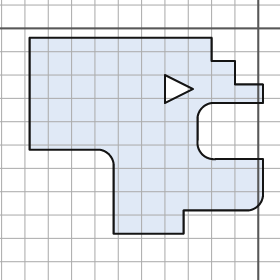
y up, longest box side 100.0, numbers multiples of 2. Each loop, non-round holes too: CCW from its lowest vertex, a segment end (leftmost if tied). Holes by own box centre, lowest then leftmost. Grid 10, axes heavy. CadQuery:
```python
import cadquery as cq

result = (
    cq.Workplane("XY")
    .moveTo(-62.0, -88.0)
    .lineTo(-32.0, -88.0)
    .lineTo(-32.0, -78.0)
    .lineTo(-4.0, -78.0)
    .threePointArc((0.0, -76.0), (2.0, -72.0))
    .lineTo(2.0, -56.0)
    .lineTo(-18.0, -56.0)
    .threePointArc((-24.0, -54.0), (-26.0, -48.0))
    .lineTo(-26.0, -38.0)
    .threePointArc((-24.0, -34.0), (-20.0, -32.0))
    .lineTo(2.0, -32.0)
    .lineTo(2.0, -24.0)
    .lineTo(-10.0, -24.0)
    .lineTo(-10.0, -14.0)
    .lineTo(-20.0, -14.0)
    .lineTo(-20.0, -4.0)
    .lineTo(-98.0, -4.0)
    .lineTo(-98.0, -52.0)
    .lineTo(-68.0, -52.0)
    .threePointArc((-64.0, -54.0), (-62.0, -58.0))
    .close()
    .moveTo(-40.0, -32.0)
    .lineTo(-28.0, -26.0)
    .lineTo(-40.0, -20.0)
    .close()
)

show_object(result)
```